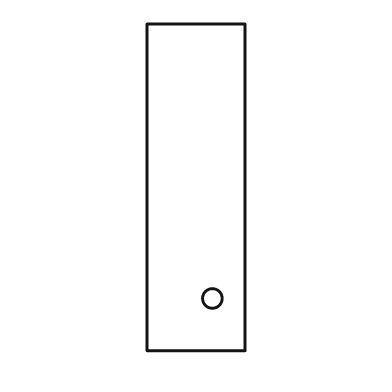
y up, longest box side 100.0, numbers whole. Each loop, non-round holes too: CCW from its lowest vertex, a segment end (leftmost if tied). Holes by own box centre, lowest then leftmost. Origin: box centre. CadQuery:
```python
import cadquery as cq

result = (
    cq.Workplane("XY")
    .moveTo(-15.0, -50.0)
    .lineTo(15.0, -50.0)
    .lineTo(15.0, 50.0)
    .lineTo(-15.0, 50.0)
    .close()
    .moveTo(5.0, -34.0)
    .circle(3.0)
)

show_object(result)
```